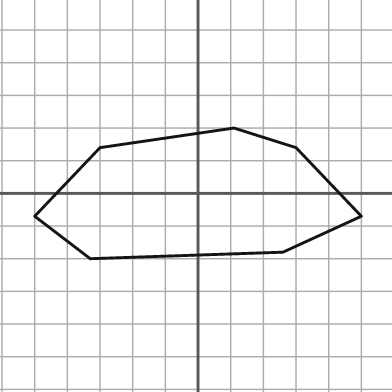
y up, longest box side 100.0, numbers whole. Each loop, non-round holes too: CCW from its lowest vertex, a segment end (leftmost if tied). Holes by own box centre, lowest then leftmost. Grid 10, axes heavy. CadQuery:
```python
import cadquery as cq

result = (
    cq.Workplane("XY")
    .moveTo(-33.0, -20.0)
    .lineTo(26.0, -18.0)
    .lineTo(50.0, -7.0)
    .lineTo(30.0, 14.0)
    .lineTo(11.0, 20.0)
    .lineTo(-30.0, 14.0)
    .lineTo(-50.0, -7.0)
    .close()
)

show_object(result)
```